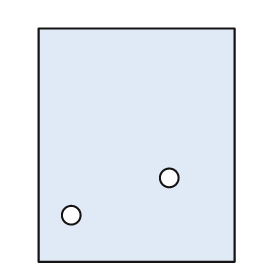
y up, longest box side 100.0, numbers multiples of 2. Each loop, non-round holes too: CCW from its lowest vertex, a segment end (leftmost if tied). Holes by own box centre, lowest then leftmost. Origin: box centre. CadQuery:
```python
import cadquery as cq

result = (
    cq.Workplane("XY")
    .moveTo(-42.0, -50.0)
    .lineTo(42.0, -50.0)
    .lineTo(42.0, 50.0)
    .lineTo(-42.0, 50.0)
    .close()
    .moveTo(-28.0, -30.0)
    .circle(4.0)
    .moveTo(14.0, -14.0)
    .circle(4.0)
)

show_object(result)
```